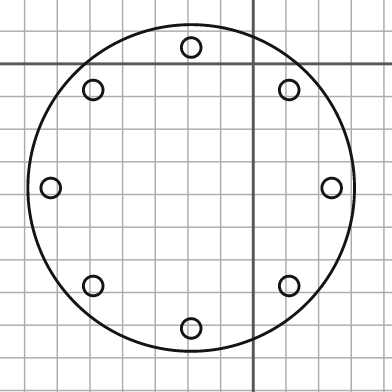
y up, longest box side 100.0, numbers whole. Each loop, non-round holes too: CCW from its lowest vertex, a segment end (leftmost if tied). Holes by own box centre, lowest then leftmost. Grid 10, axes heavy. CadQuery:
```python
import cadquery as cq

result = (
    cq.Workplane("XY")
    .moveTo(-19.0, -38.0)
    .circle(50.0)
    .moveTo(-19.0, -81.0)
    .circle(3.0)
    .moveTo(-49.0, -68.0)
    .circle(3.0)
    .moveTo(11.0, -68.0)
    .circle(3.0)
    .moveTo(-62.0, -38.0)
    .circle(3.0)
    .moveTo(24.0, -38.0)
    .circle(3.0)
    .moveTo(-49.0, -8.0)
    .circle(3.0)
    .moveTo(11.0, -8.0)
    .circle(3.0)
    .moveTo(-19.0, 5.0)
    .circle(3.0)
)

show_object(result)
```